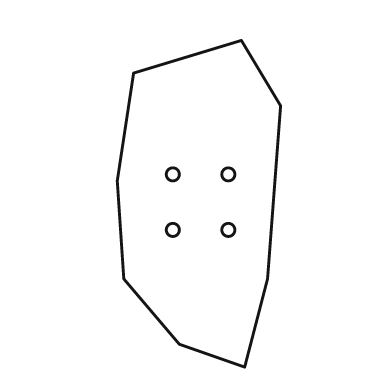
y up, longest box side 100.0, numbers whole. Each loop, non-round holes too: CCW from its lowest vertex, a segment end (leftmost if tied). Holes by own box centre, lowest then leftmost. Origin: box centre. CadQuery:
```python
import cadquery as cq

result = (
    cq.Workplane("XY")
    .moveTo(14.0, -50.0)
    .lineTo(21.0, -23.0)
    .lineTo(25.0, 30.0)
    .lineTo(13.0, 50.0)
    .lineTo(-20.0, 40.0)
    .lineTo(-25.0, 7.0)
    .lineTo(-23.0, -23.0)
    .lineTo(-6.0, -43.0)
    .close()
    .moveTo(-8.0, -8.0)
    .circle(2.0)
    .moveTo(9.0, -8.0)
    .circle(2.0)
    .moveTo(-8.0, 9.0)
    .circle(2.0)
    .moveTo(9.0, 9.0)
    .circle(2.0)
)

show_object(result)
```